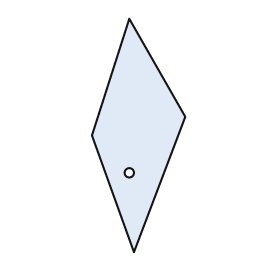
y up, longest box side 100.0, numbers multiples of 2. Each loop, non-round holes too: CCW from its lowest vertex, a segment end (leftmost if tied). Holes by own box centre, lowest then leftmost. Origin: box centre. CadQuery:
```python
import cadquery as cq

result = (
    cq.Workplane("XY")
    .moveTo(-2.0, -50.0)
    .lineTo(20.0, 8.0)
    .lineTo(-4.0, 50.0)
    .lineTo(-20.0, 0.0)
    .close()
    .moveTo(-4.0, -16.0)
    .circle(2.0)
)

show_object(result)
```